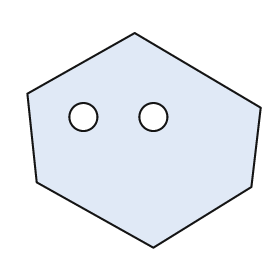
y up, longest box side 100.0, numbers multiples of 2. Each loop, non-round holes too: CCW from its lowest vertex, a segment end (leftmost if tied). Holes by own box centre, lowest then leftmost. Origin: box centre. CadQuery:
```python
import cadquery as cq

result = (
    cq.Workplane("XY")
    .moveTo(4.0, -46.0)
    .lineTo(46.0, -20.0)
    .lineTo(50.0, 14.0)
    .lineTo(-4.0, 46.0)
    .lineTo(-50.0, 20.0)
    .lineTo(-46.0, -18.0)
    .close()
    .moveTo(-26.0, 10.0)
    .circle(6.0)
    .moveTo(4.0, 10.0)
    .circle(6.0)
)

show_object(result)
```